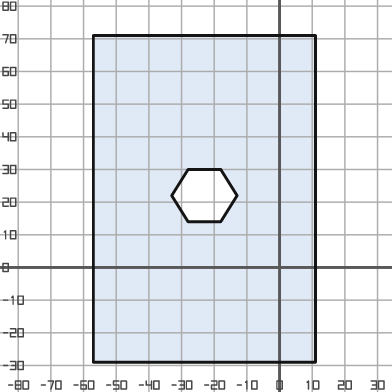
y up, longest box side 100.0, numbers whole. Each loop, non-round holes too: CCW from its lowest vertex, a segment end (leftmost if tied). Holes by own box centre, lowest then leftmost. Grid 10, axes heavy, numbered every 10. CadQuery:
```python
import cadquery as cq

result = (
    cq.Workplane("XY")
    .moveTo(-57.0, -29.0)
    .lineTo(11.0, -29.0)
    .lineTo(11.0, 71.0)
    .lineTo(-57.0, 71.0)
    .close()
    .moveTo(-28.0, 14.0)
    .lineTo(-18.0, 14.0)
    .lineTo(-13.0, 22.0)
    .lineTo(-18.0, 30.0)
    .lineTo(-28.0, 30.0)
    .lineTo(-33.0, 22.0)
    .close()
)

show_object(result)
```